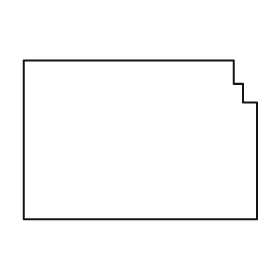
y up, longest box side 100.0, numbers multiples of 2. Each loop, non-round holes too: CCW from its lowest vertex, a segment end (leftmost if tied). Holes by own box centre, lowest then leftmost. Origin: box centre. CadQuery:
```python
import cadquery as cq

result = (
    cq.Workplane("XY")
    .moveTo(-50.0, -34.0)
    .lineTo(50.0, -34.0)
    .lineTo(50.0, 16.0)
    .lineTo(44.0, 16.0)
    .lineTo(44.0, 24.0)
    .lineTo(40.0, 24.0)
    .lineTo(40.0, 34.0)
    .lineTo(-50.0, 34.0)
    .close()
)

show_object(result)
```